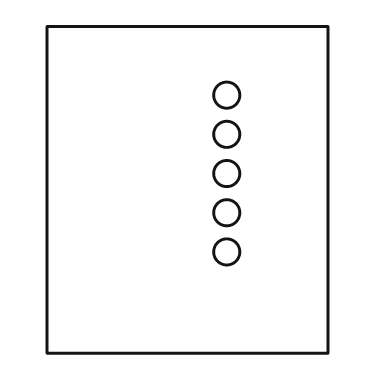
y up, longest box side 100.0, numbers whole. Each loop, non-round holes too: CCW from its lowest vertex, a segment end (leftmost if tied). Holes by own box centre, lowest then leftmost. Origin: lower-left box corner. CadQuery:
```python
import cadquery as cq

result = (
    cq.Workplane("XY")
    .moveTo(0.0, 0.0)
    .lineTo(86.0, 0.0)
    .lineTo(86.0, 100.0)
    .lineTo(0.0, 100.0)
    .close()
    .moveTo(55.0, 31.0)
    .circle(4.0)
    .moveTo(55.0, 43.0)
    .circle(4.0)
    .moveTo(55.0, 55.0)
    .circle(4.0)
    .moveTo(55.0, 67.0)
    .circle(4.0)
    .moveTo(55.0, 79.0)
    .circle(4.0)
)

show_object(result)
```